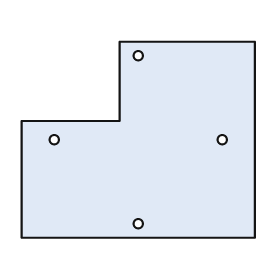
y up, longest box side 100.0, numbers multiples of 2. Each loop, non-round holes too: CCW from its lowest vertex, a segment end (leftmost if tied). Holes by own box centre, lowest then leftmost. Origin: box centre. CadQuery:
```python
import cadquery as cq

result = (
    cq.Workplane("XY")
    .moveTo(-50.0, -42.0)
    .lineTo(50.0, -42.0)
    .lineTo(50.0, 42.0)
    .lineTo(-8.0, 42.0)
    .lineTo(-8.0, 8.0)
    .lineTo(-50.0, 8.0)
    .close()
    .moveTo(0.0, -36.0)
    .circle(2.0)
    .moveTo(-36.0, 0.0)
    .circle(2.0)
    .moveTo(36.0, 0.0)
    .circle(2.0)
    .moveTo(0.0, 36.0)
    .circle(2.0)
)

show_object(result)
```